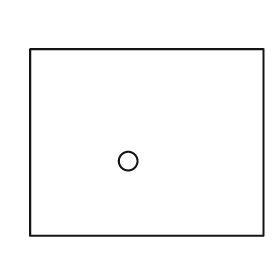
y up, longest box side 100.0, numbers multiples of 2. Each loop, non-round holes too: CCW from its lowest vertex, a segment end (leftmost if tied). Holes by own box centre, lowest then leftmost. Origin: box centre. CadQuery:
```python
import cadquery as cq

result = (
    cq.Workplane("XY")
    .moveTo(-50.0, -40.0)
    .lineTo(50.0, -40.0)
    .lineTo(50.0, 40.0)
    .lineTo(-50.0, 40.0)
    .close()
    .moveTo(-8.0, -8.0)
    .circle(4.0)
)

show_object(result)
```